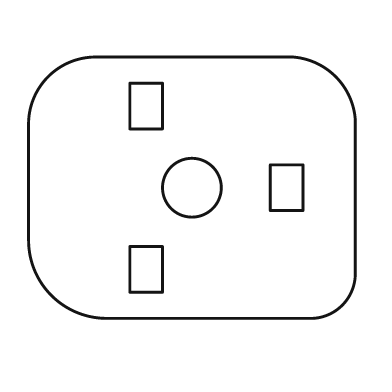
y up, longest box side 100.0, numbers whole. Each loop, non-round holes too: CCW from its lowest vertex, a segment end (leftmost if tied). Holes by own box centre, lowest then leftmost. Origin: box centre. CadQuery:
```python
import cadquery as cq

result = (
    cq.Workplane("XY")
    .moveTo(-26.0, -40.0)
    .lineTo(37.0, -40.0)
    .threePointArc((46.0, -36.0), (50.0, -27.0))
    .lineTo(50.0, 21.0)
    .threePointArc((44.0, 34.0), (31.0, 40.0))
    .lineTo(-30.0, 40.0)
    .threePointArc((-44.0, 34.0), (-50.0, 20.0))
    .lineTo(-50.0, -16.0)
    .threePointArc((-43.0, -33.0), (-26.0, -40.0))
    .close()
    .moveTo(-19.0, -32.0)
    .lineTo(-9.0, -32.0)
    .lineTo(-9.0, -18.0)
    .lineTo(-19.0, -18.0)
    .close()
    .moveTo(0.0, 0.0)
    .circle(9.0)
    .moveTo(24.0, -7.0)
    .lineTo(34.0, -7.0)
    .lineTo(34.0, 7.0)
    .lineTo(24.0, 7.0)
    .close()
    .moveTo(-19.0, 18.0)
    .lineTo(-9.0, 18.0)
    .lineTo(-9.0, 32.0)
    .lineTo(-19.0, 32.0)
    .close()
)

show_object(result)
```